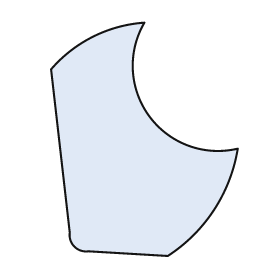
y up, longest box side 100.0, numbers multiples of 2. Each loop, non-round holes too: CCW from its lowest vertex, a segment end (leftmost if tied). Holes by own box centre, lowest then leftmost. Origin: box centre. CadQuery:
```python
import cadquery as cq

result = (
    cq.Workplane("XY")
    .moveTo(10.0, -50.0)
    .threePointArc((30.0, -30.0), (40.0, -4.0))
    .threePointArc((2.0, 10.0), (0.0, 50.0))
    .threePointArc((-22.0, 44.0), (-40.0, 30.0))
    .lineTo(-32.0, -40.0)
    .threePointArc((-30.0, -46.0), (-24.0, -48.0))
    .close()
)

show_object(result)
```